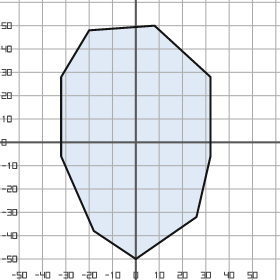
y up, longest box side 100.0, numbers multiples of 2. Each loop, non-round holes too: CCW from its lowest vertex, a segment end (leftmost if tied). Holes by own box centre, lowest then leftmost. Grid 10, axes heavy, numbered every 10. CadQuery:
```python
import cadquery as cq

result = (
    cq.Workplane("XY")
    .moveTo(0.0, -50.0)
    .lineTo(26.0, -32.0)
    .lineTo(32.0, -6.0)
    .lineTo(32.0, 28.0)
    .lineTo(8.0, 50.0)
    .lineTo(-20.0, 48.0)
    .lineTo(-32.0, 28.0)
    .lineTo(-32.0, -6.0)
    .lineTo(-18.0, -38.0)
    .close()
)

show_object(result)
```